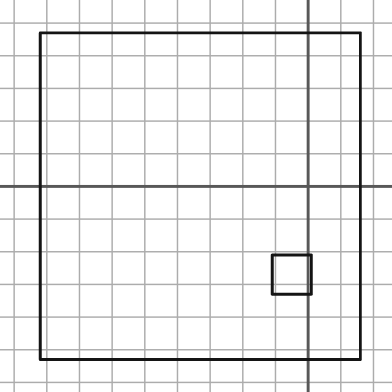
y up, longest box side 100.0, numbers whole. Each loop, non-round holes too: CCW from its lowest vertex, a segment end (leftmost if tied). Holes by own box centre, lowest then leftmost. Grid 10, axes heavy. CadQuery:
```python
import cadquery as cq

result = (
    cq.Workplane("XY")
    .moveTo(-82.0, -53.0)
    .lineTo(16.0, -53.0)
    .lineTo(16.0, 47.0)
    .lineTo(-82.0, 47.0)
    .close()
    .moveTo(-11.0, -33.0)
    .lineTo(1.0, -33.0)
    .lineTo(1.0, -21.0)
    .lineTo(-11.0, -21.0)
    .close()
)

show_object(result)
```